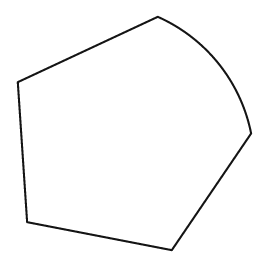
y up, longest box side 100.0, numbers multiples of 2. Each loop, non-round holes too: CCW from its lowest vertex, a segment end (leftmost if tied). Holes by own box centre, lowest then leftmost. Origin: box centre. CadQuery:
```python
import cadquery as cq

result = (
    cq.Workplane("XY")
    .moveTo(16.0, -50.0)
    .lineTo(50.0, 0.0)
    .threePointArc((36.0, 30.0), (10.0, 50.0))
    .lineTo(-50.0, 22.0)
    .lineTo(-46.0, -38.0)
    .close()
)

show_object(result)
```